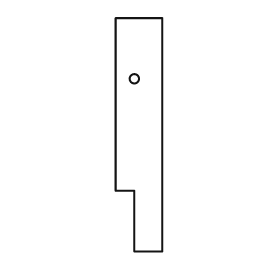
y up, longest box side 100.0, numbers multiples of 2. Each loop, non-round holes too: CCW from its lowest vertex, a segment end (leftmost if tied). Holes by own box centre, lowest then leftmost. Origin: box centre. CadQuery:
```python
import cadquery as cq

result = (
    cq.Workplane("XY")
    .moveTo(-2.0, -50.0)
    .lineTo(10.0, -50.0)
    .lineTo(10.0, 50.0)
    .lineTo(-10.0, 50.0)
    .lineTo(-10.0, -24.0)
    .lineTo(-2.0, -24.0)
    .close()
    .moveTo(-2.0, 24.0)
    .circle(2.0)
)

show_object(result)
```